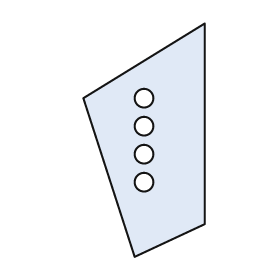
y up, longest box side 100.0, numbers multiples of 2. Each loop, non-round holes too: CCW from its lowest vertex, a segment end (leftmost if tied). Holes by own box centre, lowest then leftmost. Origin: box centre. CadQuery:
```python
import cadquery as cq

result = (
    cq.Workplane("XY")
    .moveTo(-4.0, -50.0)
    .lineTo(26.0, -36.0)
    .lineTo(26.0, 50.0)
    .lineTo(-26.0, 18.0)
    .close()
    .moveTo(0.0, -18.0)
    .circle(4.0)
    .moveTo(0.0, -6.0)
    .circle(4.0)
    .moveTo(0.0, 6.0)
    .circle(4.0)
    .moveTo(0.0, 18.0)
    .circle(4.0)
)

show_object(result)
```